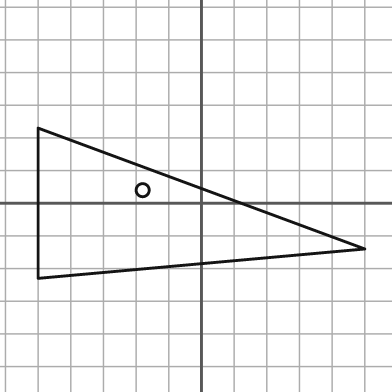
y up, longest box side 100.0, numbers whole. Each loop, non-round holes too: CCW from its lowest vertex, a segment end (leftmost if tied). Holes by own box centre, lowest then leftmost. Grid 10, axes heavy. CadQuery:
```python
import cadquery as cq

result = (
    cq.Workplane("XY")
    .moveTo(-50.0, -23.0)
    .lineTo(50.0, -14.0)
    .lineTo(-50.0, 23.0)
    .close()
    .moveTo(-18.0, 4.0)
    .circle(2.0)
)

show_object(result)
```